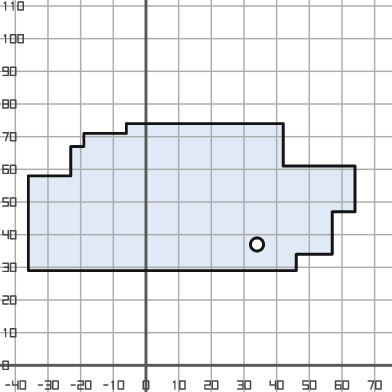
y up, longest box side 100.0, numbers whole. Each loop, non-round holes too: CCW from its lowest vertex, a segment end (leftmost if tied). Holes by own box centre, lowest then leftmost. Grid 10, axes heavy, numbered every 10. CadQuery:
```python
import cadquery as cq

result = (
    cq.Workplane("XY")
    .moveTo(-36.0, 29.0)
    .lineTo(46.0, 29.0)
    .lineTo(46.0, 34.0)
    .lineTo(57.0, 34.0)
    .lineTo(57.0, 47.0)
    .lineTo(64.0, 47.0)
    .lineTo(64.0, 61.0)
    .lineTo(42.0, 61.0)
    .lineTo(42.0, 74.0)
    .lineTo(-6.0, 74.0)
    .lineTo(-6.0, 71.0)
    .lineTo(-19.0, 71.0)
    .lineTo(-19.0, 67.0)
    .lineTo(-23.0, 67.0)
    .lineTo(-23.0, 58.0)
    .lineTo(-36.0, 58.0)
    .close()
    .moveTo(34.0, 37.0)
    .circle(2.0)
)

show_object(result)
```